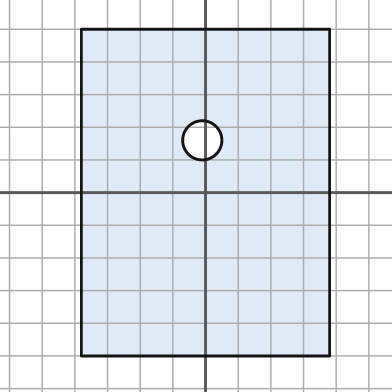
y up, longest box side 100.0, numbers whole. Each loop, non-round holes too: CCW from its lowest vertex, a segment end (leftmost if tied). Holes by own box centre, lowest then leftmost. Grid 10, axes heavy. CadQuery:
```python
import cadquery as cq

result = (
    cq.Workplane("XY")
    .moveTo(-38.0, -50.0)
    .lineTo(38.0, -50.0)
    .lineTo(38.0, 50.0)
    .lineTo(-38.0, 50.0)
    .close()
    .moveTo(-1.0, 16.0)
    .circle(6.0)
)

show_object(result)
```